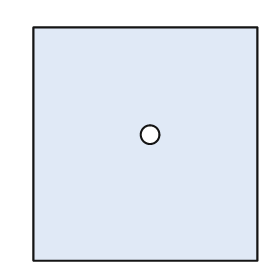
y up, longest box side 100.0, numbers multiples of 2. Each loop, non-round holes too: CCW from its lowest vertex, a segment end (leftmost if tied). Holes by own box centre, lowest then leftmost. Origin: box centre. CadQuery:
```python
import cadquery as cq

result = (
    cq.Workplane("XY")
    .moveTo(-48.0, -50.0)
    .lineTo(48.0, -50.0)
    .lineTo(48.0, 50.0)
    .lineTo(-48.0, 50.0)
    .close()
    .moveTo(2.0, 4.0)
    .circle(4.0)
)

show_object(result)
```